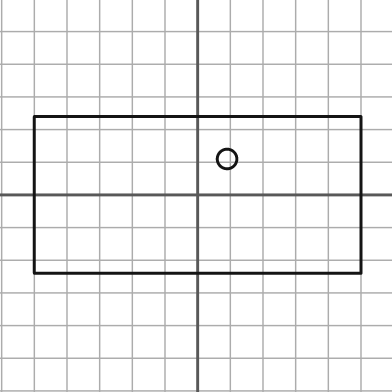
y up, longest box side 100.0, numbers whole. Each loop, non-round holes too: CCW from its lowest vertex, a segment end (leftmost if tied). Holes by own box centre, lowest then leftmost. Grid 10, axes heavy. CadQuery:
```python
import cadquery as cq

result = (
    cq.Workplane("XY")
    .moveTo(-50.0, -24.0)
    .lineTo(50.0, -24.0)
    .lineTo(50.0, 24.0)
    .lineTo(-50.0, 24.0)
    .close()
    .moveTo(9.0, 11.0)
    .circle(3.0)
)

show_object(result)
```